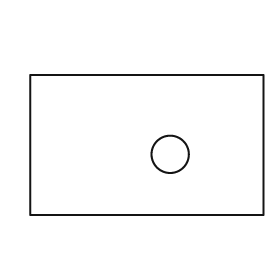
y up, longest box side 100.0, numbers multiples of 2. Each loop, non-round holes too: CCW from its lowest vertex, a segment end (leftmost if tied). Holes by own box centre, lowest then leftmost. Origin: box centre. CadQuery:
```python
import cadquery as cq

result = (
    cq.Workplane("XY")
    .moveTo(-50.0, -30.0)
    .lineTo(50.0, -30.0)
    .lineTo(50.0, 30.0)
    .lineTo(-50.0, 30.0)
    .close()
    .moveTo(10.0, -4.0)
    .circle(8.0)
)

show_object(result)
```